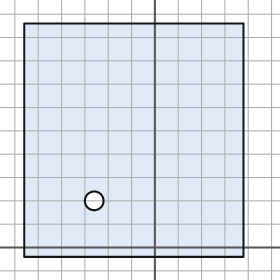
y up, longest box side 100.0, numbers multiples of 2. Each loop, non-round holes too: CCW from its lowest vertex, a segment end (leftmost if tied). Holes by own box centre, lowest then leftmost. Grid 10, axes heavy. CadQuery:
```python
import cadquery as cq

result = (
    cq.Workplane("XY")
    .moveTo(-56.0, -4.0)
    .lineTo(38.0, -4.0)
    .lineTo(38.0, 96.0)
    .lineTo(-56.0, 96.0)
    .close()
    .moveTo(-26.0, 20.0)
    .circle(4.0)
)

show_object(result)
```